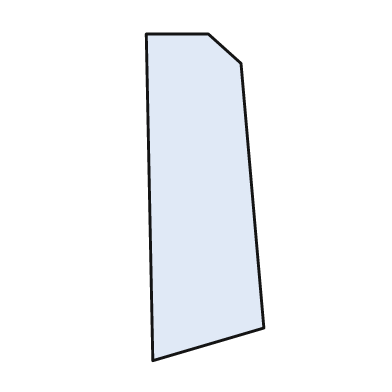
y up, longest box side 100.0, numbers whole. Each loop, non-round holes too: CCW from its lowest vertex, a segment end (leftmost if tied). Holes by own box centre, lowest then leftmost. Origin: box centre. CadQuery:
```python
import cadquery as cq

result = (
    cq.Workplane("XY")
    .moveTo(-16.0, -50.0)
    .lineTo(18.0, -40.0)
    .lineTo(11.0, 41.0)
    .lineTo(1.0, 50.0)
    .lineTo(-18.0, 50.0)
    .close()
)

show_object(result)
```